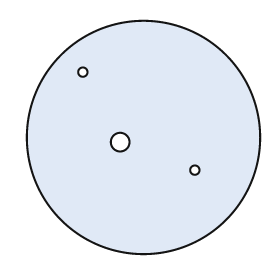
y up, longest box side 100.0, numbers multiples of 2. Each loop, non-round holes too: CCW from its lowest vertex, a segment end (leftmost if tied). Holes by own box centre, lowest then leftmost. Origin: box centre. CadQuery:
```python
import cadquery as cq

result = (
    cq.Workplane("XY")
    .moveTo(0.0, 0.0)
    .circle(50.0)
    .moveTo(22.0, -14.0)
    .circle(2.0)
    .moveTo(-10.0, -2.0)
    .circle(4.0)
    .moveTo(-26.0, 28.0)
    .circle(2.0)
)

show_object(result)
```